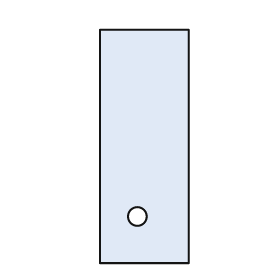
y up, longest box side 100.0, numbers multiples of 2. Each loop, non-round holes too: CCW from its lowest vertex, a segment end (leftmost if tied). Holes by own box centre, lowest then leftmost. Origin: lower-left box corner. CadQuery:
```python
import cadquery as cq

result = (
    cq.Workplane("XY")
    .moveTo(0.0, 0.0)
    .lineTo(38.0, 0.0)
    .lineTo(38.0, 100.0)
    .lineTo(0.0, 100.0)
    .close()
    .moveTo(16.0, 20.0)
    .circle(4.0)
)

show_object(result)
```